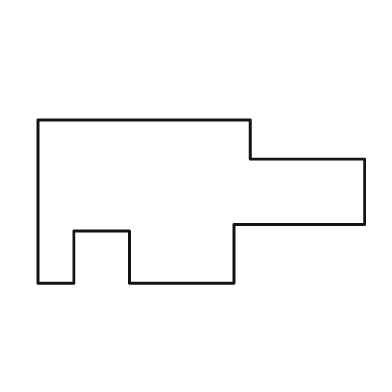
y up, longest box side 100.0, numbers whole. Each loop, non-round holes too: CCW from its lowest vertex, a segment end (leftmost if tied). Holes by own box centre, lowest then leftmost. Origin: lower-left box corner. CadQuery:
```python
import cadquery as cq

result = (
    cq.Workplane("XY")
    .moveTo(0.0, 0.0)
    .lineTo(11.0, 0.0)
    .lineTo(11.0, 16.0)
    .lineTo(28.0, 16.0)
    .lineTo(28.0, 0.0)
    .lineTo(60.0, 0.0)
    .lineTo(60.0, 18.0)
    .lineTo(100.0, 18.0)
    .lineTo(100.0, 38.0)
    .lineTo(65.0, 38.0)
    .lineTo(65.0, 50.0)
    .lineTo(0.0, 50.0)
    .close()
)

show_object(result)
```